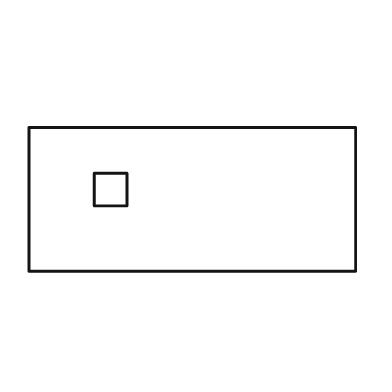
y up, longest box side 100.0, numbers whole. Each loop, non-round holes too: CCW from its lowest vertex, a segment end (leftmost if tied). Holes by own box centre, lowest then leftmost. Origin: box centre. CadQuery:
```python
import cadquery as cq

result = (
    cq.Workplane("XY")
    .moveTo(-50.0, -22.0)
    .lineTo(50.0, -22.0)
    .lineTo(50.0, 22.0)
    .lineTo(-50.0, 22.0)
    .close()
    .moveTo(-30.0, -2.0)
    .lineTo(-20.0, -2.0)
    .lineTo(-20.0, 8.0)
    .lineTo(-30.0, 8.0)
    .close()
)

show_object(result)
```